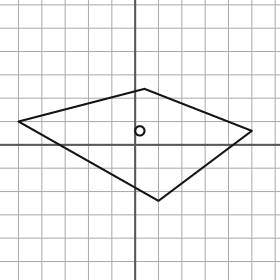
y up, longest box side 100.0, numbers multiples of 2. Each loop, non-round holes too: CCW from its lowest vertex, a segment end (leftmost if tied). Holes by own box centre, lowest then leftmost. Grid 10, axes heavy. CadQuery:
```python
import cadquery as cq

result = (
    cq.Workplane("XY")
    .moveTo(10.0, -24.0)
    .lineTo(50.0, 6.0)
    .lineTo(4.0, 24.0)
    .lineTo(-50.0, 10.0)
    .close()
    .moveTo(2.0, 6.0)
    .circle(2.0)
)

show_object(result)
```